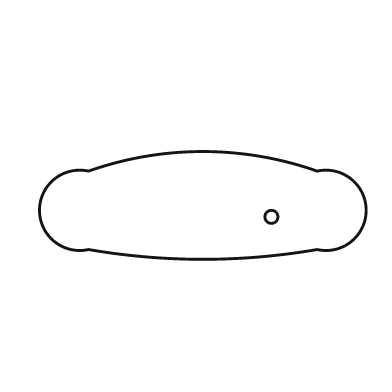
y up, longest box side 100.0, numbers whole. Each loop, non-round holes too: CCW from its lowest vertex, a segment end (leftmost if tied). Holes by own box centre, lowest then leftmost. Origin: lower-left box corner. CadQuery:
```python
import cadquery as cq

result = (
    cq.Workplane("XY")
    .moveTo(15.0, 3.0)
    .threePointArc((50.0, 0.0), (85.0, 3.0))
    .threePointArc((100.0, 15.0), (85.0, 27.0))
    .threePointArc((50.0, 33.0), (15.0, 27.0))
    .threePointArc((0.0, 15.0), (15.0, 3.0))
    .close()
    .moveTo(71.0, 13.0)
    .circle(2.0)
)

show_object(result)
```